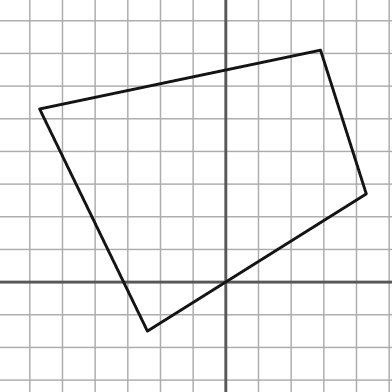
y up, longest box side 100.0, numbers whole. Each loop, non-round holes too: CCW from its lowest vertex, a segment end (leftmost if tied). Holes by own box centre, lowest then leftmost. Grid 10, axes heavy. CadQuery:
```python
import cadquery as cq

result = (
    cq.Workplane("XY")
    .moveTo(-24.0, -15.0)
    .lineTo(43.0, 27.0)
    .lineTo(29.0, 71.0)
    .lineTo(-57.0, 53.0)
    .close()
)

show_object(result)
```